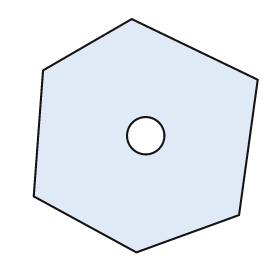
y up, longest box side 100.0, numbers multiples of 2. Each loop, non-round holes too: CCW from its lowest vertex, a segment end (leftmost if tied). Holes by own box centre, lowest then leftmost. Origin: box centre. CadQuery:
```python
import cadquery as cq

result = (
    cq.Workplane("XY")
    .moveTo(-4.0, -50.0)
    .lineTo(40.0, -34.0)
    .lineTo(48.0, 24.0)
    .lineTo(-6.0, 50.0)
    .lineTo(-44.0, 28.0)
    .lineTo(-48.0, -26.0)
    .close()
    .moveTo(0.0, 0.0)
    .circle(8.0)
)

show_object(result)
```